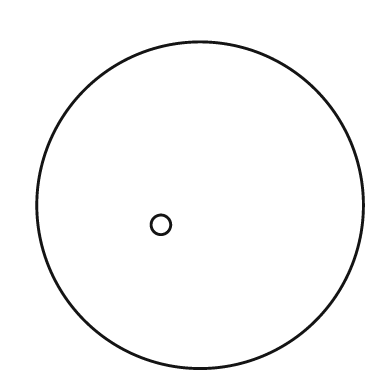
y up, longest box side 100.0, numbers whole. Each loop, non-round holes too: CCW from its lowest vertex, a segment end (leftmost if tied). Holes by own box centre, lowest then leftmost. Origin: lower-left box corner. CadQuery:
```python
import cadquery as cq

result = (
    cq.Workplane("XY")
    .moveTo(50.0, 50.0)
    .circle(50.0)
    .moveTo(38.0, 44.0)
    .circle(3.0)
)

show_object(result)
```